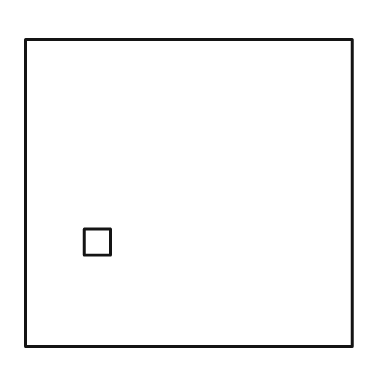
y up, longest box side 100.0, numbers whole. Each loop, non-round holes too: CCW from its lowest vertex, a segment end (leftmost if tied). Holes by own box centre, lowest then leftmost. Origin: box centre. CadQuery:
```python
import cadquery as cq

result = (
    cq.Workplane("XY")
    .moveTo(-50.0, -47.0)
    .lineTo(50.0, -47.0)
    .lineTo(50.0, 47.0)
    .lineTo(-50.0, 47.0)
    .close()
    .moveTo(-32.0, -19.0)
    .lineTo(-24.0, -19.0)
    .lineTo(-24.0, -11.0)
    .lineTo(-32.0, -11.0)
    .close()
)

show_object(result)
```